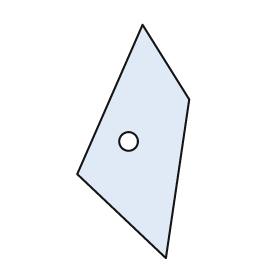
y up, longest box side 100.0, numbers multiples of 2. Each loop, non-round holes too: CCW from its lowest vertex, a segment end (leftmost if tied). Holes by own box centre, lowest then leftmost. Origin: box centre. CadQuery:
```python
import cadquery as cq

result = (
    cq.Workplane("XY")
    .moveTo(14.0, -50.0)
    .lineTo(24.0, 18.0)
    .lineTo(4.0, 50.0)
    .lineTo(-24.0, -14.0)
    .close()
    .moveTo(-2.0, 0.0)
    .circle(4.0)
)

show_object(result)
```